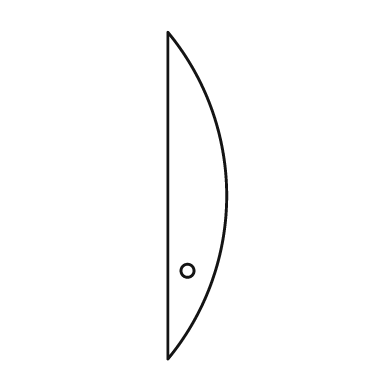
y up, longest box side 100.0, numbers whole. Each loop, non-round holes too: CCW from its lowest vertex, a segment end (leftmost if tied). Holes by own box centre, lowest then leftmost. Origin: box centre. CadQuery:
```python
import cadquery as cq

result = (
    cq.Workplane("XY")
    .moveTo(-9.0, -50.0)
    .threePointArc((9.0, 0.0), (-9.0, 50.0))
    .close()
    .moveTo(-3.0, -23.0)
    .circle(2.0)
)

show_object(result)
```